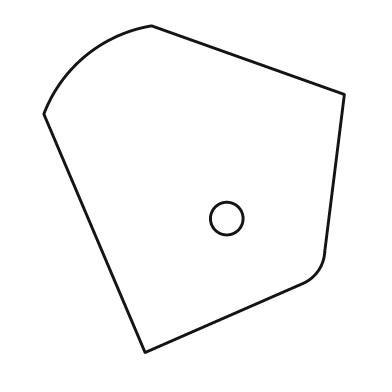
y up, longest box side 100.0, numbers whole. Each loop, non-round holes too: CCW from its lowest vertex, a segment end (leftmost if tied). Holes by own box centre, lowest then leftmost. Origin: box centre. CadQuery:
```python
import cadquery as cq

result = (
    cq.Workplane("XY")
    .moveTo(-15.0, -50.0)
    .lineTo(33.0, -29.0)
    .threePointArc((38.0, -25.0), (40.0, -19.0))
    .lineTo(46.0, 29.0)
    .lineTo(-13.0, 50.0)
    .threePointArc((-33.0, 41.0), (-46.0, 23.0))
    .close()
    .moveTo(10.0, -9.0)
    .circle(5.0)
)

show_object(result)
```